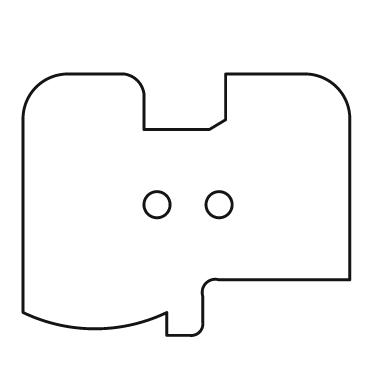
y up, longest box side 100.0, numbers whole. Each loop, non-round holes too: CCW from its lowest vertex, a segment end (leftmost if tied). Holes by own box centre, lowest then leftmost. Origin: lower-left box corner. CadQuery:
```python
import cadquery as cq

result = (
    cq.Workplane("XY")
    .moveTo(44.0, 0.0)
    .lineTo(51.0, 0.0)
    .threePointArc((54.0, 1.0), (55.0, 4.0))
    .lineTo(55.0, 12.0)
    .threePointArc((56.0, 16.0), (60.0, 17.0))
    .lineTo(100.0, 17.0)
    .lineTo(100.0, 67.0)
    .threePointArc((96.0, 76.0), (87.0, 80.0))
    .lineTo(62.0, 80.0)
    .lineTo(62.0, 66.0)
    .lineTo(57.0, 63.0)
    .lineTo(37.0, 63.0)
    .lineTo(37.0, 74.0)
    .threePointArc((35.0, 78.0), (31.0, 80.0))
    .lineTo(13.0, 80.0)
    .threePointArc((4.0, 76.0), (0.0, 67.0))
    .lineTo(0.0, 7.0)
    .threePointArc((22.0, 2.0), (44.0, 7.0))
    .close()
    .moveTo(41.0, 40.0)
    .circle(4.0)
    .moveTo(60.0, 40.0)
    .circle(4.0)
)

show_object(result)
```